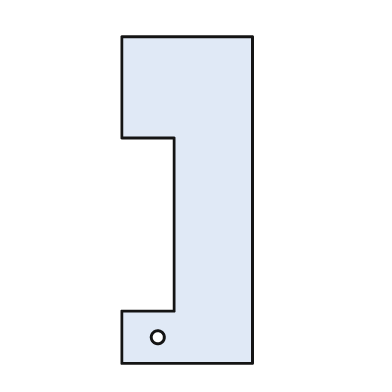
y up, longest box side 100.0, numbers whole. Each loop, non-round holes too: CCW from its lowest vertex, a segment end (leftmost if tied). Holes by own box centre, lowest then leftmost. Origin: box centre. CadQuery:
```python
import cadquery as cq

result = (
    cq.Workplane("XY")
    .moveTo(-20.0, -50.0)
    .lineTo(20.0, -50.0)
    .lineTo(20.0, 50.0)
    .lineTo(-20.0, 50.0)
    .lineTo(-20.0, 19.0)
    .lineTo(-4.0, 19.0)
    .lineTo(-4.0, -34.0)
    .lineTo(-20.0, -34.0)
    .close()
    .moveTo(-9.0, -42.0)
    .circle(2.0)
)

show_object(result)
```